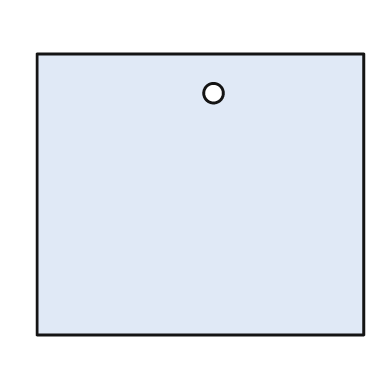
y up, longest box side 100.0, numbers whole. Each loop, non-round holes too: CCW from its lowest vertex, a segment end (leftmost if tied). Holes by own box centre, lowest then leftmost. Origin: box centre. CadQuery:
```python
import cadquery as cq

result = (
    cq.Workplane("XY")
    .moveTo(-50.0, -43.0)
    .lineTo(50.0, -43.0)
    .lineTo(50.0, 43.0)
    .lineTo(-50.0, 43.0)
    .close()
    .moveTo(4.0, 31.0)
    .circle(3.0)
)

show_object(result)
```